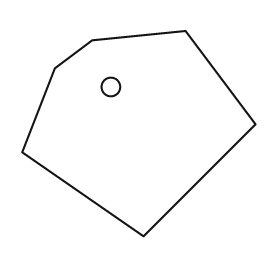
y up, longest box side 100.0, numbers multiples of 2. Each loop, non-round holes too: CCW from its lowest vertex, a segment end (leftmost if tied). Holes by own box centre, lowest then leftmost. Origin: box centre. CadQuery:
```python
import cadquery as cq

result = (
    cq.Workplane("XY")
    .moveTo(2.0, -44.0)
    .lineTo(50.0, 4.0)
    .lineTo(20.0, 44.0)
    .lineTo(-20.0, 40.0)
    .lineTo(-36.0, 28.0)
    .lineTo(-50.0, -8.0)
    .close()
    .moveTo(-12.0, 20.0)
    .circle(4.0)
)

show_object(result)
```